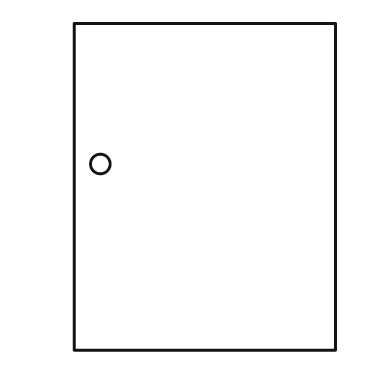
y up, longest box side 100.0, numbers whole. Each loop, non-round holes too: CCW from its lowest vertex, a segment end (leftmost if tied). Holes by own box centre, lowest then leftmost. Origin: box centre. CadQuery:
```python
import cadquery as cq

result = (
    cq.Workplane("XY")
    .moveTo(-40.0, -50.0)
    .lineTo(40.0, -50.0)
    .lineTo(40.0, 50.0)
    .lineTo(-40.0, 50.0)
    .close()
    .moveTo(-32.0, 7.0)
    .circle(3.0)
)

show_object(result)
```